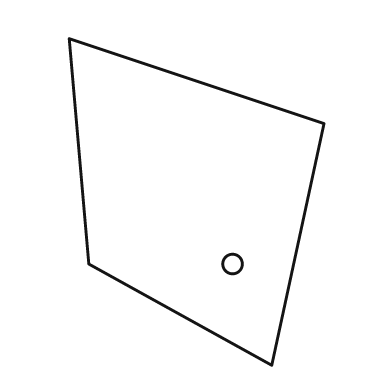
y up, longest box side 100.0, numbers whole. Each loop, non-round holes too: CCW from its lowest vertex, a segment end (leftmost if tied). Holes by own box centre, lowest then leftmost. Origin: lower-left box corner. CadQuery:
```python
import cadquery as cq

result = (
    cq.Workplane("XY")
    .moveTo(62.0, 0.0)
    .lineTo(78.0, 74.0)
    .lineTo(0.0, 100.0)
    .lineTo(6.0, 31.0)
    .close()
    .moveTo(50.0, 31.0)
    .circle(3.0)
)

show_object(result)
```